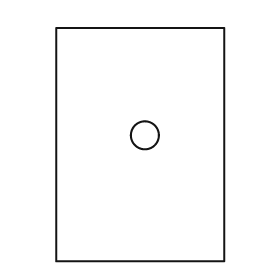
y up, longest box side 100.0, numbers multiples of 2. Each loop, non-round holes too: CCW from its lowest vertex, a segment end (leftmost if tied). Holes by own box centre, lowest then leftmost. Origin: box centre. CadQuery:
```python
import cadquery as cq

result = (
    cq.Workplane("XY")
    .moveTo(-36.0, -50.0)
    .lineTo(36.0, -50.0)
    .lineTo(36.0, 50.0)
    .lineTo(-36.0, 50.0)
    .close()
    .moveTo(2.0, 4.0)
    .circle(6.0)
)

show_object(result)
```